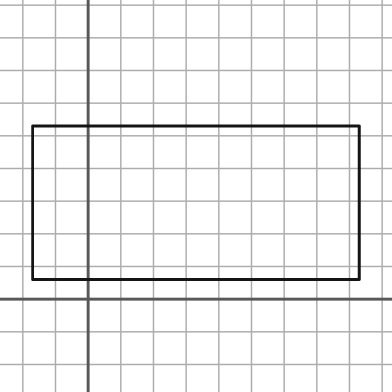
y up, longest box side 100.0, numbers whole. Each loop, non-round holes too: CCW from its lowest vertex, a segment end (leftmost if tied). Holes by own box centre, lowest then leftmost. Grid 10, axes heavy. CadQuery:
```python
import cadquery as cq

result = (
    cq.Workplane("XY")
    .moveTo(-17.0, 6.0)
    .lineTo(83.0, 6.0)
    .lineTo(83.0, 53.0)
    .lineTo(-17.0, 53.0)
    .close()
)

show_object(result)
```